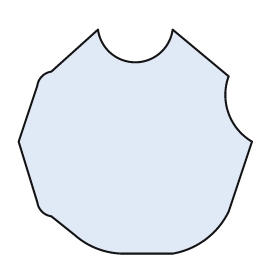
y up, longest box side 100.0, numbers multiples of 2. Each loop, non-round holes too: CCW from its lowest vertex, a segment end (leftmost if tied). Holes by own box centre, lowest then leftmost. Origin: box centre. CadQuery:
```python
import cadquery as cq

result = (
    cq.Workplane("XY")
    .moveTo(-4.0, -48.0)
    .lineTo(16.0, -48.0)
    .threePointArc((30.0, -42.0), (40.0, -30.0))
    .lineTo(50.0, 0.0)
    .threePointArc((40.0, 12.0), (40.0, 28.0))
    .lineTo(16.0, 48.0)
    .threePointArc((0.0, 34.0), (-16.0, 48.0))
    .lineTo(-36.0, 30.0)
    .threePointArc((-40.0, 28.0), (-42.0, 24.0))
    .lineTo(-50.0, 0.0)
    .lineTo(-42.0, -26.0)
    .threePointArc((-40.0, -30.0), (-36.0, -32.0))
    .lineTo(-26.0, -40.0)
    .threePointArc((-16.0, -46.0), (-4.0, -48.0))
    .close()
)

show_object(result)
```